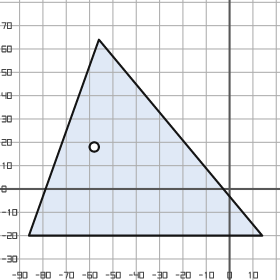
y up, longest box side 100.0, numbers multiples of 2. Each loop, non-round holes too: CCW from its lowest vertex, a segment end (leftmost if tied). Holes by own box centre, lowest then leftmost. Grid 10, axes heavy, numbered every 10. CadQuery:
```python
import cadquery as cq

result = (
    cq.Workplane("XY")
    .moveTo(-86.0, -20.0)
    .lineTo(14.0, -20.0)
    .lineTo(-56.0, 64.0)
    .close()
    .moveTo(-58.0, 18.0)
    .circle(2.0)
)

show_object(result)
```